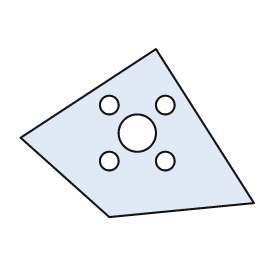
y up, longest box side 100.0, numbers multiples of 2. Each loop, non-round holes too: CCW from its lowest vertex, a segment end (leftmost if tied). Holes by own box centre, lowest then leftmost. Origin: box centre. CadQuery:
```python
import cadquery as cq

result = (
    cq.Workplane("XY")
    .moveTo(-12.0, -36.0)
    .lineTo(50.0, -30.0)
    .lineTo(8.0, 36.0)
    .lineTo(-50.0, -2.0)
    .close()
    .moveTo(-12.0, -12.0)
    .circle(4.0)
    .moveTo(12.0, -12.0)
    .circle(4.0)
    .moveTo(0.0, 0.0)
    .circle(8.0)
    .moveTo(-12.0, 12.0)
    .circle(4.0)
    .moveTo(12.0, 12.0)
    .circle(4.0)
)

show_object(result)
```